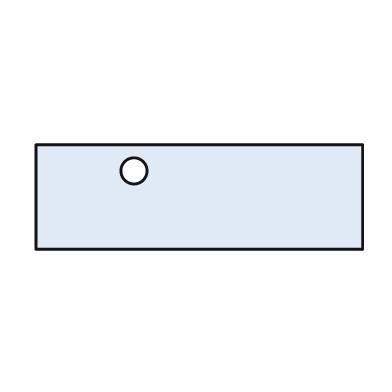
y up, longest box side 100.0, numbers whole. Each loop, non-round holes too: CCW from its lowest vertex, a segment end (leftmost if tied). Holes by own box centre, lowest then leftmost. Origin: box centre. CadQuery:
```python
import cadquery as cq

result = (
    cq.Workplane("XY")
    .moveTo(-50.0, -16.0)
    .lineTo(50.0, -16.0)
    .lineTo(50.0, 16.0)
    .lineTo(-50.0, 16.0)
    .close()
    .moveTo(-20.0, 8.0)
    .circle(4.0)
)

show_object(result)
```